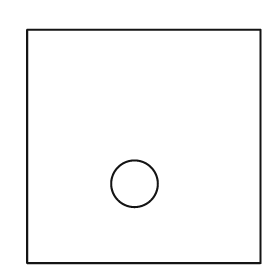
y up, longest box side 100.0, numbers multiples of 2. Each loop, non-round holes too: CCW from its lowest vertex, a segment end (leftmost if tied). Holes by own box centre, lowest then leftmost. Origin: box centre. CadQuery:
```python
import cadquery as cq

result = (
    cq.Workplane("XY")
    .moveTo(-50.0, -50.0)
    .lineTo(50.0, -50.0)
    .lineTo(50.0, 50.0)
    .lineTo(-50.0, 50.0)
    .close()
    .moveTo(-4.0, -16.0)
    .circle(10.0)
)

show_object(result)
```